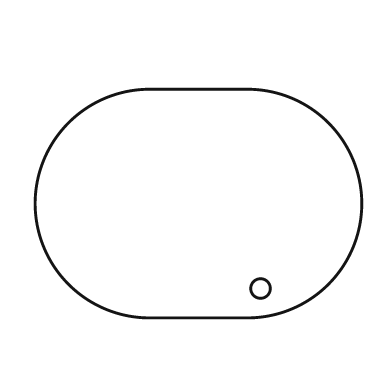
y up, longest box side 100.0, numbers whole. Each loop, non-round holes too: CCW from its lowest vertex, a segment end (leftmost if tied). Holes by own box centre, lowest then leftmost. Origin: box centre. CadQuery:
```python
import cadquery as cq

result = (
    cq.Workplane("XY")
    .moveTo(-15.0, -35.0)
    .lineTo(15.0, -35.0)
    .threePointArc((50.0, 0.0), (15.0, 35.0))
    .lineTo(-15.0, 35.0)
    .threePointArc((-50.0, 0.0), (-15.0, -35.0))
    .close()
    .moveTo(19.0, -26.0)
    .circle(3.0)
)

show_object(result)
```